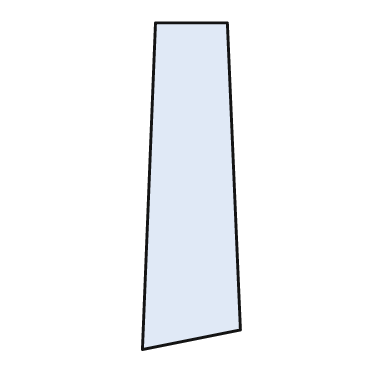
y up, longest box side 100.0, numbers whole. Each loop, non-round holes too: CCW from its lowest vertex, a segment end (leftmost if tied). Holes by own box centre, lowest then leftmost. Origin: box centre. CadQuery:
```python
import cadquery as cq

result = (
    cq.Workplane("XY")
    .moveTo(-15.0, -50.0)
    .lineTo(15.0, -44.0)
    .lineTo(11.0, 50.0)
    .lineTo(-11.0, 50.0)
    .close()
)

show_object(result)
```